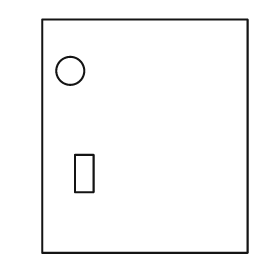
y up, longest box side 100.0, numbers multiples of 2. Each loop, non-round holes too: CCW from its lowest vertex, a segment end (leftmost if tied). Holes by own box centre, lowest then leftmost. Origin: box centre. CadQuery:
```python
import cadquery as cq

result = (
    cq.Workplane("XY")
    .moveTo(-44.0, -50.0)
    .lineTo(44.0, -50.0)
    .lineTo(44.0, 50.0)
    .lineTo(-44.0, 50.0)
    .close()
    .moveTo(-30.0, -24.0)
    .lineTo(-22.0, -24.0)
    .lineTo(-22.0, -8.0)
    .lineTo(-30.0, -8.0)
    .close()
    .moveTo(-32.0, 28.0)
    .circle(6.0)
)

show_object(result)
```